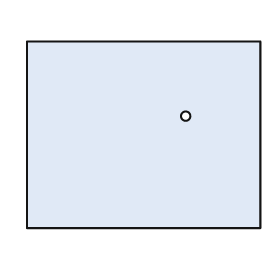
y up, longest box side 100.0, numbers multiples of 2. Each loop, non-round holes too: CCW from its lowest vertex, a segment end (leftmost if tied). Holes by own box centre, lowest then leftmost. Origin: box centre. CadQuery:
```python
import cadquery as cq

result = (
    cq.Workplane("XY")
    .moveTo(-50.0, -40.0)
    .lineTo(50.0, -40.0)
    .lineTo(50.0, 40.0)
    .lineTo(-50.0, 40.0)
    .close()
    .moveTo(18.0, 8.0)
    .circle(2.0)
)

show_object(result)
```